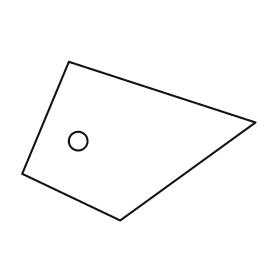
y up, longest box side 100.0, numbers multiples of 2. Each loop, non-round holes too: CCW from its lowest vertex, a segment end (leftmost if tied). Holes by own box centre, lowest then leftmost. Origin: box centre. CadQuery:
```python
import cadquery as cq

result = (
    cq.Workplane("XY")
    .moveTo(-8.0, -34.0)
    .lineTo(50.0, 8.0)
    .lineTo(-30.0, 34.0)
    .lineTo(-50.0, -14.0)
    .close()
    .moveTo(-26.0, 0.0)
    .circle(4.0)
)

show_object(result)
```